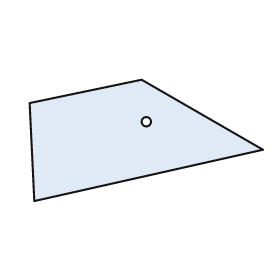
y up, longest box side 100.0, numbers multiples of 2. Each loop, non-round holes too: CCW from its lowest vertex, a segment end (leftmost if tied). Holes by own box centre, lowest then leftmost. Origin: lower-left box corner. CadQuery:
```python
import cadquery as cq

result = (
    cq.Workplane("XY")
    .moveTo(2.0, 0.0)
    .lineTo(100.0, 22.0)
    .lineTo(48.0, 52.0)
    .lineTo(0.0, 42.0)
    .close()
    .moveTo(50.0, 34.0)
    .circle(2.0)
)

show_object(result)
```